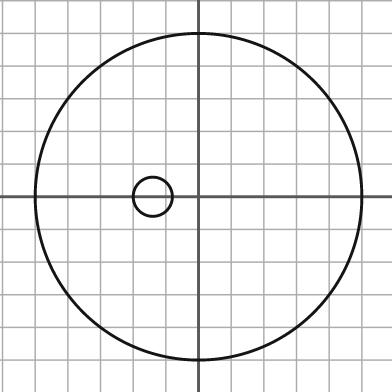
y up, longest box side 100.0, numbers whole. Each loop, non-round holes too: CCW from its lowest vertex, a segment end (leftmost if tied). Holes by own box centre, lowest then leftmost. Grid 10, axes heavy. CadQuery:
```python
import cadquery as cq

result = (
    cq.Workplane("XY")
    .moveTo(0.0, 0.0)
    .circle(50.0)
    .moveTo(-14.0, 0.0)
    .circle(6.0)
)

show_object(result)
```